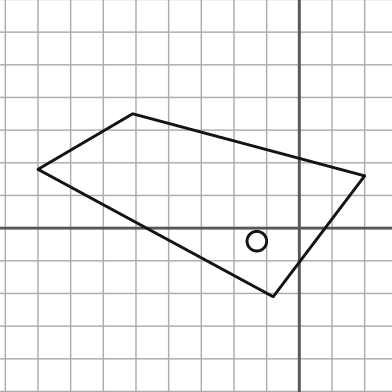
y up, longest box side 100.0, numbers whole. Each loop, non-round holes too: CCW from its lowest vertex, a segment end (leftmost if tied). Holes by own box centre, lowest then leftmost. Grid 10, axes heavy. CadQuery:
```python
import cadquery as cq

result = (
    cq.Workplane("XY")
    .moveTo(-8.0, -21.0)
    .lineTo(20.0, 16.0)
    .lineTo(-51.0, 35.0)
    .lineTo(-80.0, 18.0)
    .close()
    .moveTo(-13.0, -4.0)
    .circle(3.0)
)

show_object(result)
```